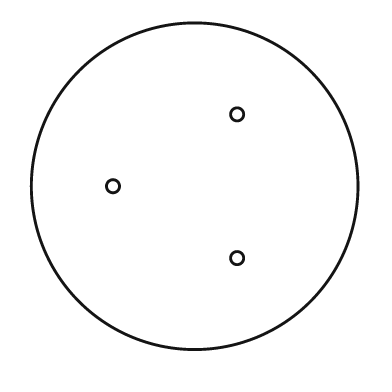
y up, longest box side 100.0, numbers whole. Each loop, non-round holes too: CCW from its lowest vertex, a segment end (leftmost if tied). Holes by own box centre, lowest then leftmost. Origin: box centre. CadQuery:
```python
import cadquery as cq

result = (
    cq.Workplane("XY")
    .moveTo(0.0, 0.0)
    .circle(50.0)
    .moveTo(13.0, -22.0)
    .circle(2.0)
    .moveTo(-25.0, 0.0)
    .circle(2.0)
    .moveTo(13.0, 22.0)
    .circle(2.0)
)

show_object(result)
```